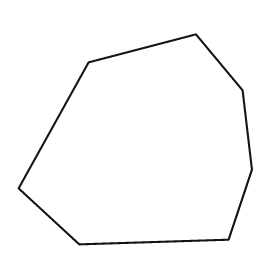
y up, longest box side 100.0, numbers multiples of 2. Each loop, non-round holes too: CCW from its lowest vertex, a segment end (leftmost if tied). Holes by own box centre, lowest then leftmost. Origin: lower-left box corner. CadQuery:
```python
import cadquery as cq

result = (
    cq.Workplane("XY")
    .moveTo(26.0, 0.0)
    .lineTo(90.0, 2.0)
    .lineTo(100.0, 32.0)
    .lineTo(96.0, 66.0)
    .lineTo(76.0, 90.0)
    .lineTo(30.0, 78.0)
    .lineTo(0.0, 24.0)
    .close()
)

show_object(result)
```